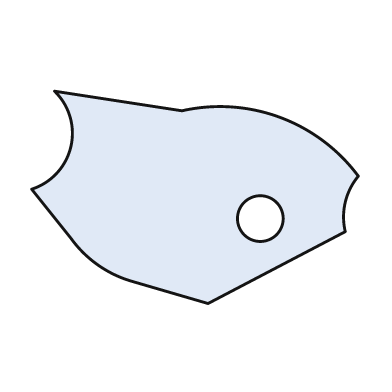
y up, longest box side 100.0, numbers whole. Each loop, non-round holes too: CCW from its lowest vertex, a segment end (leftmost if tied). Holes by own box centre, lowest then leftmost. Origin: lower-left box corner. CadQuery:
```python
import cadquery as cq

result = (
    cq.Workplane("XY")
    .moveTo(54.0, 0.0)
    .lineTo(96.0, 22.0)
    .threePointArc((96.0, 31.0), (100.0, 39.0))
    .threePointArc((76.0, 57.0), (46.0, 59.0))
    .lineTo(7.0, 65.0)
    .threePointArc((12.0, 48.0), (0.0, 35.0))
    .lineTo(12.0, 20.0)
    .threePointArc((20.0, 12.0), (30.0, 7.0))
    .close()
    .moveTo(70.0, 26.0)
    .circle(7.0)
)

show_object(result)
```